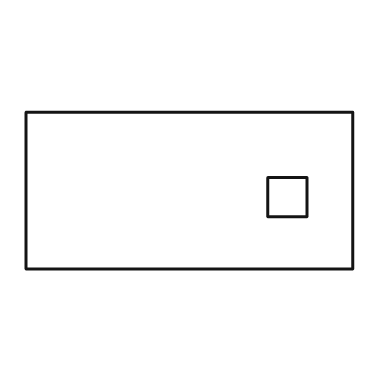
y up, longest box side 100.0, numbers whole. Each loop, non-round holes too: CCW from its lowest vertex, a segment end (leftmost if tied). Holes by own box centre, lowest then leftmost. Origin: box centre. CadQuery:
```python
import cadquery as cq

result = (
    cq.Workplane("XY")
    .moveTo(-50.0, -24.0)
    .lineTo(50.0, -24.0)
    .lineTo(50.0, 24.0)
    .lineTo(-50.0, 24.0)
    .close()
    .moveTo(24.0, -8.0)
    .lineTo(36.0, -8.0)
    .lineTo(36.0, 4.0)
    .lineTo(24.0, 4.0)
    .close()
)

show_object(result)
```